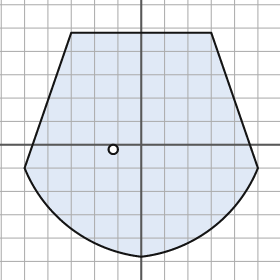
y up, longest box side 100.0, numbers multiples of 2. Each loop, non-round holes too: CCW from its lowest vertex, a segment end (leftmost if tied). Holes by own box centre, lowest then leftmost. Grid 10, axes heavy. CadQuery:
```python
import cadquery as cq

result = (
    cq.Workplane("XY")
    .moveTo(0.0, -48.0)
    .threePointArc((30.0, -36.0), (50.0, -10.0))
    .lineTo(30.0, 48.0)
    .lineTo(-30.0, 48.0)
    .lineTo(-50.0, -10.0)
    .threePointArc((-30.0, -36.0), (0.0, -48.0))
    .close()
    .moveTo(-12.0, -2.0)
    .circle(2.0)
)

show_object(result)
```